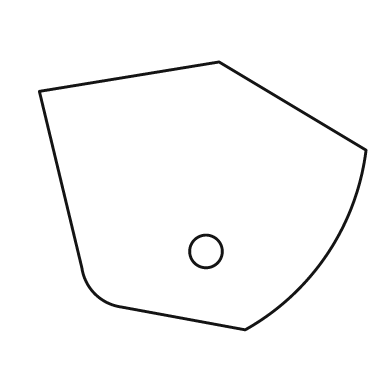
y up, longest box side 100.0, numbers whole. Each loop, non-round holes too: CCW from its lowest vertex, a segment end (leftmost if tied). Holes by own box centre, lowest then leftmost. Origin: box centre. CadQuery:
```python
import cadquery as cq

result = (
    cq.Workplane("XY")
    .moveTo(13.0, -41.0)
    .threePointArc((38.0, -18.0), (50.0, 14.0))
    .lineTo(5.0, 41.0)
    .lineTo(-50.0, 32.0)
    .lineTo(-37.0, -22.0)
    .threePointArc((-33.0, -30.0), (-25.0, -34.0))
    .close()
    .moveTo(1.0, -17.0)
    .circle(5.0)
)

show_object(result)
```